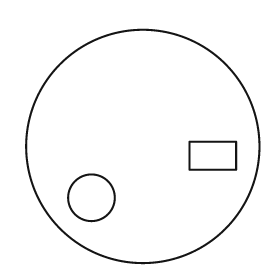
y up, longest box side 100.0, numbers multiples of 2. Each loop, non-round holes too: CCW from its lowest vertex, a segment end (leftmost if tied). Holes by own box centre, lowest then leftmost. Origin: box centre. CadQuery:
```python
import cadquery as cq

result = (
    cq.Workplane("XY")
    .moveTo(0.0, 0.0)
    .circle(50.0)
    .moveTo(-22.0, -22.0)
    .circle(10.0)
    .moveTo(20.0, -10.0)
    .lineTo(40.0, -10.0)
    .lineTo(40.0, 2.0)
    .lineTo(20.0, 2.0)
    .close()
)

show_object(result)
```